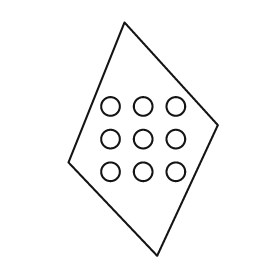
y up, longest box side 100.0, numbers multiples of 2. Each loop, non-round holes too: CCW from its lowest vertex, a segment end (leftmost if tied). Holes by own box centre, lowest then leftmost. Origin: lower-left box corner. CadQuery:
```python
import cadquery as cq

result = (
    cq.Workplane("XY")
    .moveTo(38.0, 0.0)
    .lineTo(64.0, 56.0)
    .lineTo(24.0, 100.0)
    .lineTo(0.0, 40.0)
    .close()
    .moveTo(18.0, 36.0)
    .circle(4.0)
    .moveTo(32.0, 36.0)
    .circle(4.0)
    .moveTo(46.0, 36.0)
    .circle(4.0)
    .moveTo(18.0, 50.0)
    .circle(4.0)
    .moveTo(32.0, 50.0)
    .circle(4.0)
    .moveTo(46.0, 50.0)
    .circle(4.0)
    .moveTo(18.0, 64.0)
    .circle(4.0)
    .moveTo(32.0, 64.0)
    .circle(4.0)
    .moveTo(46.0, 64.0)
    .circle(4.0)
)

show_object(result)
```